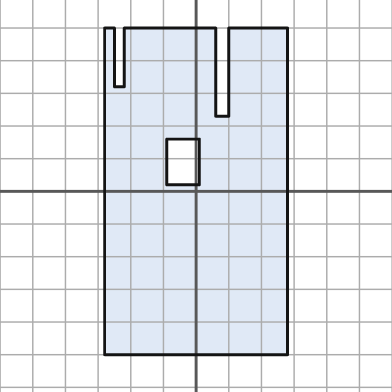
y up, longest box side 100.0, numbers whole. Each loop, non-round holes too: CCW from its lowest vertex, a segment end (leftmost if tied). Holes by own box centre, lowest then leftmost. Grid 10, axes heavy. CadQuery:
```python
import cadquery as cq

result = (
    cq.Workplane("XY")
    .moveTo(-28.0, -50.0)
    .lineTo(28.0, -50.0)
    .lineTo(28.0, 50.0)
    .lineTo(10.0, 50.0)
    .lineTo(10.0, 23.0)
    .lineTo(6.0, 23.0)
    .lineTo(6.0, 50.0)
    .lineTo(-22.0, 50.0)
    .lineTo(-22.0, 32.0)
    .lineTo(-25.0, 32.0)
    .lineTo(-25.0, 50.0)
    .lineTo(-28.0, 50.0)
    .close()
    .moveTo(-9.0, 2.0)
    .lineTo(1.0, 2.0)
    .lineTo(1.0, 16.0)
    .lineTo(-9.0, 16.0)
    .close()
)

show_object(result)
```